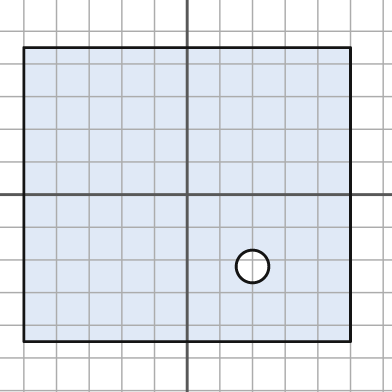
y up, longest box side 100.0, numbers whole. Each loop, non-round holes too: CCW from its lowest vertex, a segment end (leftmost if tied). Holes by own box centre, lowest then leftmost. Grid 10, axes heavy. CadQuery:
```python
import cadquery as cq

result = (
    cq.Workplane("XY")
    .moveTo(-50.0, -45.0)
    .lineTo(50.0, -45.0)
    .lineTo(50.0, 45.0)
    .lineTo(-50.0, 45.0)
    .close()
    .moveTo(20.0, -22.0)
    .circle(5.0)
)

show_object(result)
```